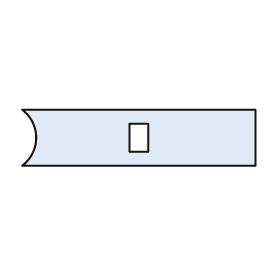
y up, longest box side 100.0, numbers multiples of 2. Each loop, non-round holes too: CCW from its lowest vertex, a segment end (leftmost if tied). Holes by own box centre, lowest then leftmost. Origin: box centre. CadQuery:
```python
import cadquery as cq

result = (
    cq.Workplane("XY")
    .moveTo(-50.0, -12.0)
    .lineTo(50.0, -12.0)
    .lineTo(50.0, 12.0)
    .lineTo(-50.0, 12.0)
    .threePointArc((-44.0, 0.0), (-50.0, -12.0))
    .close()
    .moveTo(-4.0, -6.0)
    .lineTo(4.0, -6.0)
    .lineTo(4.0, 6.0)
    .lineTo(-4.0, 6.0)
    .close()
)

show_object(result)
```